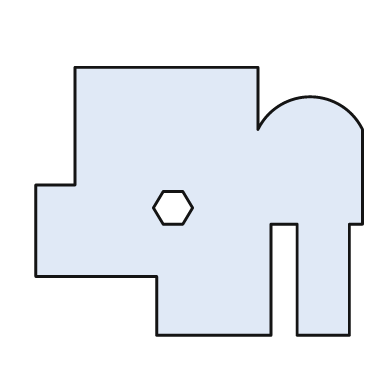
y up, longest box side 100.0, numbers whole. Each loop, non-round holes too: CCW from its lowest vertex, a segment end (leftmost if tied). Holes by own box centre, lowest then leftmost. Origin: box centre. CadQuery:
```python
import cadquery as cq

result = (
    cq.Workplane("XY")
    .moveTo(-13.0, -41.0)
    .lineTo(22.0, -41.0)
    .lineTo(22.0, -7.0)
    .lineTo(30.0, -7.0)
    .lineTo(30.0, -41.0)
    .lineTo(46.0, -41.0)
    .lineTo(46.0, -7.0)
    .lineTo(50.0, -7.0)
    .lineTo(50.0, 22.0)
    .threePointArc((34.0, 32.0), (18.0, 22.0))
    .lineTo(18.0, 41.0)
    .lineTo(-38.0, 41.0)
    .lineTo(-38.0, 5.0)
    .lineTo(-50.0, 5.0)
    .lineTo(-50.0, -23.0)
    .lineTo(-13.0, -23.0)
    .close()
    .moveTo(-11.0, -7.0)
    .lineTo(-5.0, -7.0)
    .lineTo(-2.0, -2.0)
    .lineTo(-5.0, 3.0)
    .lineTo(-11.0, 3.0)
    .lineTo(-14.0, -2.0)
    .close()
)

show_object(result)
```